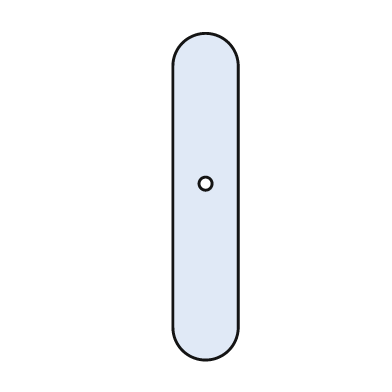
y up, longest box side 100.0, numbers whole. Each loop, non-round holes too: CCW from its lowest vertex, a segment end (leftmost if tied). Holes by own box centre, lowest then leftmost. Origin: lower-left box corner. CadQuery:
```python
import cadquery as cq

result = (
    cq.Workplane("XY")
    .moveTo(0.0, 10.0)
    .threePointArc((10.0, 0.0), (20.0, 10.0))
    .lineTo(20.0, 90.0)
    .threePointArc((10.0, 100.0), (0.0, 90.0))
    .close()
    .moveTo(10.0, 54.0)
    .circle(2.0)
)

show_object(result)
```